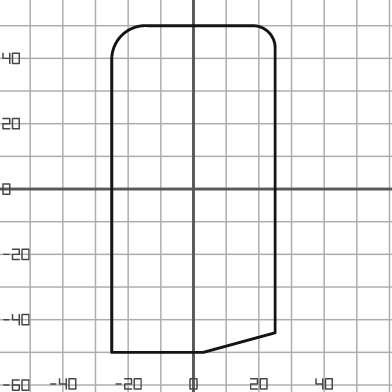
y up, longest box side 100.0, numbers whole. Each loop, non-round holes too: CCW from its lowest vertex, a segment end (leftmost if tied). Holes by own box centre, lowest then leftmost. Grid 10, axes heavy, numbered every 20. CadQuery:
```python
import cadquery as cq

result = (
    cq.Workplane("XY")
    .moveTo(-25.0, -50.0)
    .lineTo(3.0, -50.0)
    .lineTo(25.0, -44.0)
    .lineTo(25.0, 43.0)
    .threePointArc((23.0, 48.0), (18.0, 50.0))
    .lineTo(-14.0, 50.0)
    .threePointArc((-22.0, 47.0), (-25.0, 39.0))
    .close()
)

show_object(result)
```